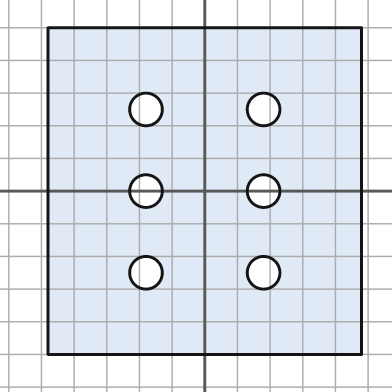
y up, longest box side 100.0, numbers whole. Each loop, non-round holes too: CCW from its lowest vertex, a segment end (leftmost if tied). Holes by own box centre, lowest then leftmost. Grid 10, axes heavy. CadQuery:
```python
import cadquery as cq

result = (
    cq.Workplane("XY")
    .moveTo(-48.0, -50.0)
    .lineTo(48.0, -50.0)
    .lineTo(48.0, 50.0)
    .lineTo(-48.0, 50.0)
    .close()
    .moveTo(-18.0, -25.0)
    .circle(5.0)
    .moveTo(18.0, -25.0)
    .circle(5.0)
    .moveTo(-18.0, 0.0)
    .circle(5.0)
    .moveTo(18.0, 0.0)
    .circle(5.0)
    .moveTo(-18.0, 25.0)
    .circle(5.0)
    .moveTo(18.0, 25.0)
    .circle(5.0)
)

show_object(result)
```